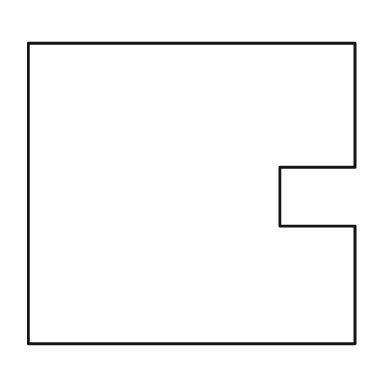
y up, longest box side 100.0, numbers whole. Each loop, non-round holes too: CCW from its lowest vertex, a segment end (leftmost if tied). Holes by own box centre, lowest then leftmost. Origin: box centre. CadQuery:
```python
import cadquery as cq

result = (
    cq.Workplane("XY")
    .moveTo(-50.0, -46.0)
    .lineTo(50.0, -46.0)
    .lineTo(50.0, -10.0)
    .lineTo(27.0, -10.0)
    .lineTo(27.0, 8.0)
    .lineTo(50.0, 8.0)
    .lineTo(50.0, 46.0)
    .lineTo(-50.0, 46.0)
    .close()
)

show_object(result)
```